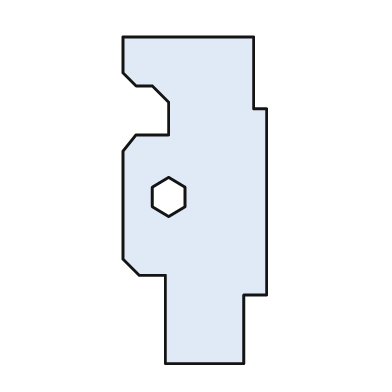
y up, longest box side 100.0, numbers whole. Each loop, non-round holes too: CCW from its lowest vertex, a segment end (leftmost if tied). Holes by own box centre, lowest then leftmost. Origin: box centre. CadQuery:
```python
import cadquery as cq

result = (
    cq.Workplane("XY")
    .moveTo(-9.0, -50.0)
    .lineTo(15.0, -50.0)
    .lineTo(15.0, -29.0)
    .lineTo(22.0, -29.0)
    .lineTo(22.0, 28.0)
    .lineTo(18.0, 28.0)
    .lineTo(18.0, 50.0)
    .lineTo(-22.0, 50.0)
    .lineTo(-22.0, 39.0)
    .lineTo(-18.0, 35.0)
    .lineTo(-13.0, 35.0)
    .lineTo(-8.0, 30.0)
    .lineTo(-8.0, 20.0)
    .lineTo(-18.0, 20.0)
    .lineTo(-22.0, 15.0)
    .lineTo(-22.0, -18.0)
    .lineTo(-17.0, -23.0)
    .lineTo(-9.0, -23.0)
    .close()
    .moveTo(-8.0, -5.0)
    .lineTo(-3.0, -2.0)
    .lineTo(-3.0, 4.0)
    .lineTo(-8.0, 7.0)
    .lineTo(-13.0, 4.0)
    .lineTo(-13.0, -2.0)
    .close()
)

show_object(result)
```